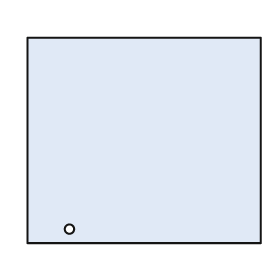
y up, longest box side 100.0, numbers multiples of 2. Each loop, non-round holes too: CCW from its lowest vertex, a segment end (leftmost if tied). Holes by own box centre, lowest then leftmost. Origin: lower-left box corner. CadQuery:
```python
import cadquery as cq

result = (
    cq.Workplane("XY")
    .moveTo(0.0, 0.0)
    .lineTo(100.0, 0.0)
    .lineTo(100.0, 88.0)
    .lineTo(0.0, 88.0)
    .close()
    .moveTo(18.0, 6.0)
    .circle(2.0)
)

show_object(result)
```